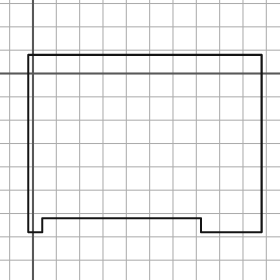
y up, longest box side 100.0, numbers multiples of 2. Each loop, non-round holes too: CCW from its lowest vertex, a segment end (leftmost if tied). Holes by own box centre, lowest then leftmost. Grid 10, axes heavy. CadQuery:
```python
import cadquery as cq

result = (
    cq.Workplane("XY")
    .moveTo(-2.0, -68.0)
    .lineTo(4.0, -68.0)
    .lineTo(4.0, -62.0)
    .lineTo(72.0, -62.0)
    .lineTo(72.0, -68.0)
    .lineTo(98.0, -68.0)
    .lineTo(98.0, 8.0)
    .lineTo(-2.0, 8.0)
    .close()
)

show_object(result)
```